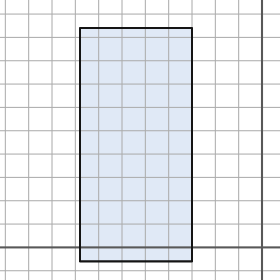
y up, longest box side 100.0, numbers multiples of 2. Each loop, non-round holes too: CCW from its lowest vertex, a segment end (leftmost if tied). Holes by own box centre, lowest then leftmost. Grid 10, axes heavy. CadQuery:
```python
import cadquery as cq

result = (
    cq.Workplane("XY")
    .moveTo(-78.0, -6.0)
    .lineTo(-30.0, -6.0)
    .lineTo(-30.0, 94.0)
    .lineTo(-78.0, 94.0)
    .close()
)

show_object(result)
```